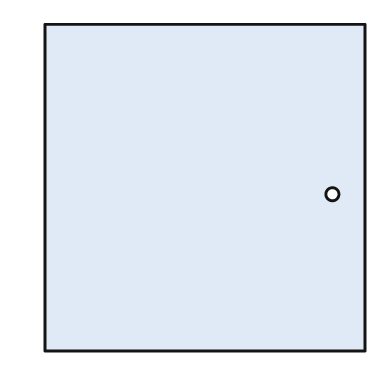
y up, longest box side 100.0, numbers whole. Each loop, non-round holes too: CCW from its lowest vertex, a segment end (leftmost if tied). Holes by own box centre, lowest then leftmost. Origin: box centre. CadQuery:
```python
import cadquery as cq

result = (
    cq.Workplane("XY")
    .moveTo(-49.0, -50.0)
    .lineTo(49.0, -50.0)
    .lineTo(49.0, 50.0)
    .lineTo(-49.0, 50.0)
    .close()
    .moveTo(39.0, -2.0)
    .circle(2.0)
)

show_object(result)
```